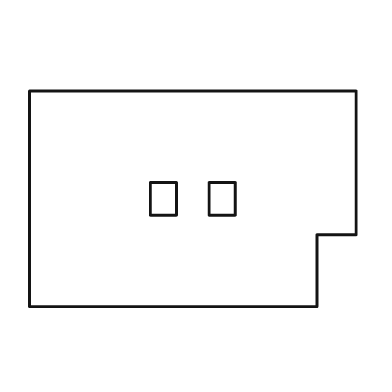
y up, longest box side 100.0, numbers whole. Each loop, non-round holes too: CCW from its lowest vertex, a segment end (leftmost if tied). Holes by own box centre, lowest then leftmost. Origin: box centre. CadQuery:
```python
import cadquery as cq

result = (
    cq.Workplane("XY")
    .moveTo(-50.0, -33.0)
    .lineTo(38.0, -33.0)
    .lineTo(38.0, -11.0)
    .lineTo(50.0, -11.0)
    .lineTo(50.0, 33.0)
    .lineTo(-50.0, 33.0)
    .close()
    .moveTo(-13.0, -5.0)
    .lineTo(-5.0, -5.0)
    .lineTo(-5.0, 5.0)
    .lineTo(-13.0, 5.0)
    .close()
    .moveTo(5.0, -5.0)
    .lineTo(13.0, -5.0)
    .lineTo(13.0, 5.0)
    .lineTo(5.0, 5.0)
    .close()
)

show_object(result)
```